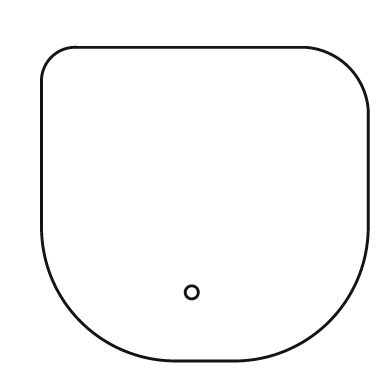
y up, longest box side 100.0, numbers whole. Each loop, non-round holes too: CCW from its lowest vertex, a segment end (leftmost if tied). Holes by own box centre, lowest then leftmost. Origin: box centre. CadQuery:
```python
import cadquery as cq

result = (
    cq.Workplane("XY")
    .moveTo(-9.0, -48.0)
    .lineTo(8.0, -48.0)
    .threePointArc((38.0, -36.0), (50.0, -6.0))
    .lineTo(50.0, 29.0)
    .threePointArc((44.0, 42.0), (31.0, 48.0))
    .lineTo(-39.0, 48.0)
    .threePointArc((-47.0, 45.0), (-50.0, 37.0))
    .lineTo(-50.0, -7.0)
    .threePointArc((-38.0, -36.0), (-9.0, -48.0))
    .close()
    .moveTo(-4.0, -27.0)
    .circle(2.0)
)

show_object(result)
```